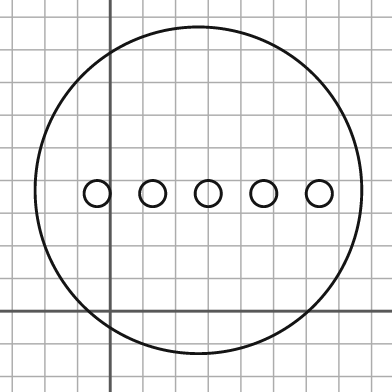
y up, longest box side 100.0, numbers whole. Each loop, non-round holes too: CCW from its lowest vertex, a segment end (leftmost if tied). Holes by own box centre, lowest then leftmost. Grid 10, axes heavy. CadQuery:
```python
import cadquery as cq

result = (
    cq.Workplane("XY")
    .moveTo(27.0, 37.0)
    .circle(50.0)
    .moveTo(-4.0, 36.0)
    .circle(4.0)
    .moveTo(13.0, 36.0)
    .circle(4.0)
    .moveTo(30.0, 36.0)
    .circle(4.0)
    .moveTo(47.0, 36.0)
    .circle(4.0)
    .moveTo(64.0, 36.0)
    .circle(4.0)
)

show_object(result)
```